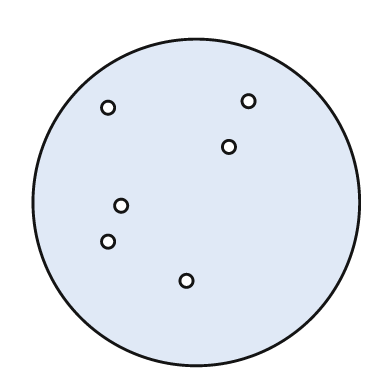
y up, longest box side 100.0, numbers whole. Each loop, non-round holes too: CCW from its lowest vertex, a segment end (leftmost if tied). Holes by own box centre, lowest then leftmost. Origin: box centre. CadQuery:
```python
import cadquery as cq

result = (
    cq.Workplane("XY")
    .moveTo(0.0, 0.0)
    .circle(50.0)
    .moveTo(-3.0, -24.0)
    .circle(2.0)
    .moveTo(-27.0, -12.0)
    .circle(2.0)
    .moveTo(-23.0, -1.0)
    .circle(2.0)
    .moveTo(10.0, 17.0)
    .circle(2.0)
    .moveTo(-27.0, 29.0)
    .circle(2.0)
    .moveTo(16.0, 31.0)
    .circle(2.0)
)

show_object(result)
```